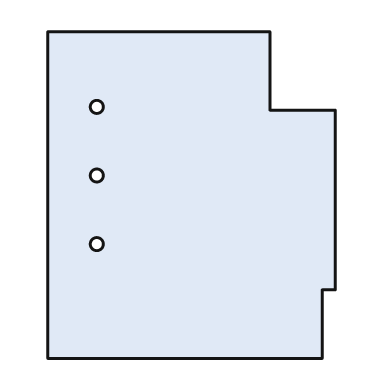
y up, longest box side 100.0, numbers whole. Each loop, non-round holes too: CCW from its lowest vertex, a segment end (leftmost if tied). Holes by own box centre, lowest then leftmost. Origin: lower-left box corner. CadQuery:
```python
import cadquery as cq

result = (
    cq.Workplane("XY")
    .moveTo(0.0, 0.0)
    .lineTo(84.0, 0.0)
    .lineTo(84.0, 21.0)
    .lineTo(88.0, 21.0)
    .lineTo(88.0, 76.0)
    .lineTo(68.0, 76.0)
    .lineTo(68.0, 100.0)
    .lineTo(0.0, 100.0)
    .close()
    .moveTo(15.0, 35.0)
    .circle(2.0)
    .moveTo(15.0, 56.0)
    .circle(2.0)
    .moveTo(15.0, 77.0)
    .circle(2.0)
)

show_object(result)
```